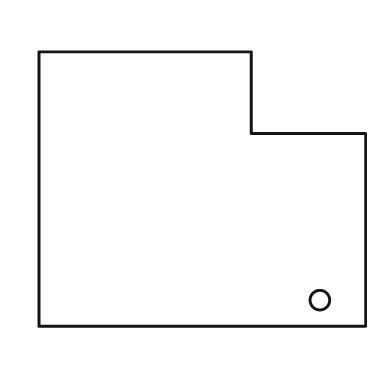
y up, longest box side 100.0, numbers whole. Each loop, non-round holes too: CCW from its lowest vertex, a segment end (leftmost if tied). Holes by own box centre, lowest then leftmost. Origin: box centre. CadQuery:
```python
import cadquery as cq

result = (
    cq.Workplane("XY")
    .moveTo(-50.0, -42.0)
    .lineTo(50.0, -42.0)
    .lineTo(50.0, 17.0)
    .lineTo(15.0, 17.0)
    .lineTo(15.0, 42.0)
    .lineTo(-50.0, 42.0)
    .close()
    .moveTo(36.0, -34.0)
    .circle(3.0)
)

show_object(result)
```